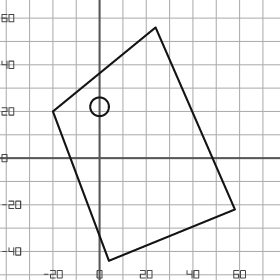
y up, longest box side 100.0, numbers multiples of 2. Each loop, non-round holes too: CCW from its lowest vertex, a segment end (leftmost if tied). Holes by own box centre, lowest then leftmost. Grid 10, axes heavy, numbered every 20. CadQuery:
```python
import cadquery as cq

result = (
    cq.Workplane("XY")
    .moveTo(4.0, -44.0)
    .lineTo(58.0, -22.0)
    .lineTo(24.0, 56.0)
    .lineTo(-20.0, 20.0)
    .close()
    .moveTo(0.0, 22.0)
    .circle(4.0)
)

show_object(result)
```